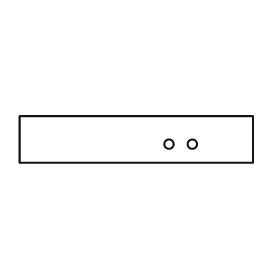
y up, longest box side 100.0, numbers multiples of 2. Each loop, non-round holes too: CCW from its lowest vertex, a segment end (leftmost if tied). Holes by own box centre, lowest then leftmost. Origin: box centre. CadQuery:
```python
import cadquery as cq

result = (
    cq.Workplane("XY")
    .moveTo(-50.0, -10.0)
    .lineTo(50.0, -10.0)
    .lineTo(50.0, 10.0)
    .lineTo(-50.0, 10.0)
    .close()
    .moveTo(14.0, -2.0)
    .circle(2.0)
    .moveTo(24.0, -2.0)
    .circle(2.0)
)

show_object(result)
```